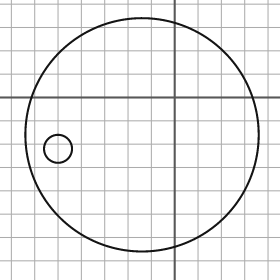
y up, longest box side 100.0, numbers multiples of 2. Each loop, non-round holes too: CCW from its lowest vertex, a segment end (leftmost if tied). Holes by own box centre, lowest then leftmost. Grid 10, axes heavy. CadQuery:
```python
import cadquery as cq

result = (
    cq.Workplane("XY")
    .moveTo(-14.0, -16.0)
    .circle(50.0)
    .moveTo(-50.0, -22.0)
    .circle(6.0)
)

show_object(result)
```